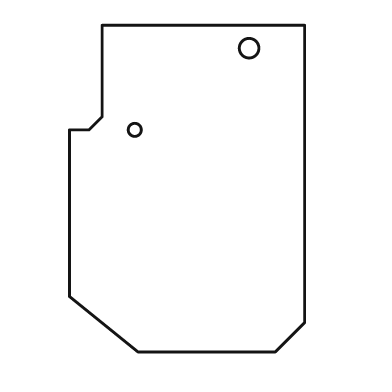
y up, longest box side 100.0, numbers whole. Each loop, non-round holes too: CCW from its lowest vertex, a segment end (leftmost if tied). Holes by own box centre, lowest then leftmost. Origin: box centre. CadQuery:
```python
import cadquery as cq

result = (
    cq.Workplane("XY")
    .moveTo(-15.0, -50.0)
    .lineTo(27.0, -50.0)
    .lineTo(36.0, -41.0)
    .lineTo(36.0, 50.0)
    .lineTo(-26.0, 50.0)
    .lineTo(-26.0, 22.0)
    .lineTo(-30.0, 18.0)
    .lineTo(-36.0, 18.0)
    .lineTo(-36.0, -33.0)
    .close()
    .moveTo(-16.0, 18.0)
    .circle(2.0)
    .moveTo(19.0, 43.0)
    .circle(3.0)
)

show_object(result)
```